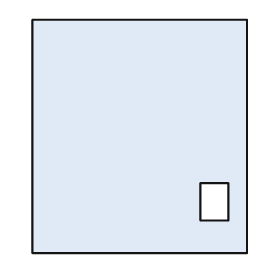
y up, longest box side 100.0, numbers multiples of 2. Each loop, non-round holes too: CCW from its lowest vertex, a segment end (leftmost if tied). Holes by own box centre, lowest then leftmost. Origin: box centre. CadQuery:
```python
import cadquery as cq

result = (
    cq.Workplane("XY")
    .moveTo(-46.0, -50.0)
    .lineTo(46.0, -50.0)
    .lineTo(46.0, 50.0)
    .lineTo(-46.0, 50.0)
    .close()
    .moveTo(26.0, -36.0)
    .lineTo(38.0, -36.0)
    .lineTo(38.0, -20.0)
    .lineTo(26.0, -20.0)
    .close()
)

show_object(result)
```